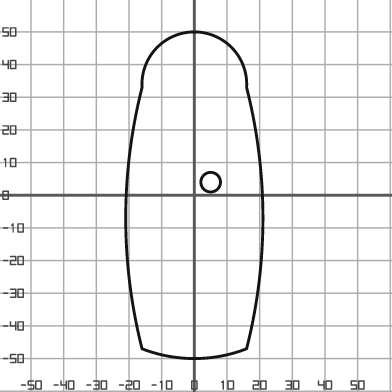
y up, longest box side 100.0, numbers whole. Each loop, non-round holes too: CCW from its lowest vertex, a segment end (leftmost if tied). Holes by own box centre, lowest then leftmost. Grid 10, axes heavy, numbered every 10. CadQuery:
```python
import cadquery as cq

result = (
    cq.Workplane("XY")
    .moveTo(-16.0, -47.0)
    .threePointArc((0.0, -50.0), (16.0, -47.0))
    .threePointArc((21.0, -7.0), (16.0, 33.0))
    .threePointArc((0.0, 50.0), (-16.0, 33.0))
    .threePointArc((-21.0, -7.0), (-16.0, -47.0))
    .close()
    .moveTo(5.0, 4.0)
    .circle(3.0)
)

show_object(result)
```